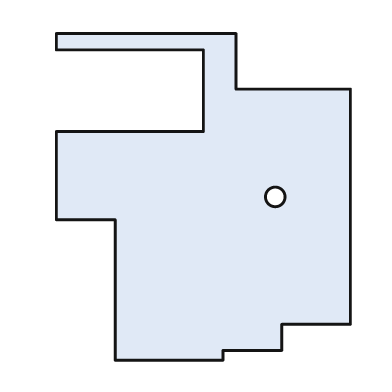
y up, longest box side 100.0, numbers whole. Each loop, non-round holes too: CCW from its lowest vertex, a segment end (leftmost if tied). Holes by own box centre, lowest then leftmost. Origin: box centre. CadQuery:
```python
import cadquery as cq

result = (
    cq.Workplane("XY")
    .moveTo(-27.0, -50.0)
    .lineTo(6.0, -50.0)
    .lineTo(6.0, -47.0)
    .lineTo(24.0, -47.0)
    .lineTo(24.0, -39.0)
    .lineTo(45.0, -39.0)
    .lineTo(45.0, 33.0)
    .lineTo(10.0, 33.0)
    .lineTo(10.0, 50.0)
    .lineTo(-45.0, 50.0)
    .lineTo(-45.0, 45.0)
    .lineTo(0.0, 45.0)
    .lineTo(0.0, 20.0)
    .lineTo(-45.0, 20.0)
    .lineTo(-45.0, -7.0)
    .lineTo(-27.0, -7.0)
    .close()
    .moveTo(22.0, 0.0)
    .circle(3.0)
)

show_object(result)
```